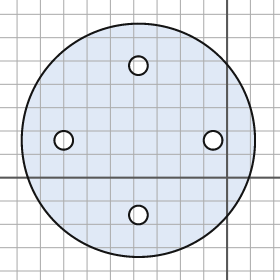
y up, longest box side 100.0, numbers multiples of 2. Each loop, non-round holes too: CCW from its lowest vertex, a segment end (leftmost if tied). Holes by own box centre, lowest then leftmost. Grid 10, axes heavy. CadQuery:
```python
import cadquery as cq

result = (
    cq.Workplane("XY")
    .moveTo(-38.0, 16.0)
    .circle(50.0)
    .moveTo(-38.0, -16.0)
    .circle(4.0)
    .moveTo(-70.0, 16.0)
    .circle(4.0)
    .moveTo(-6.0, 16.0)
    .circle(4.0)
    .moveTo(-38.0, 48.0)
    .circle(4.0)
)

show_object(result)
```